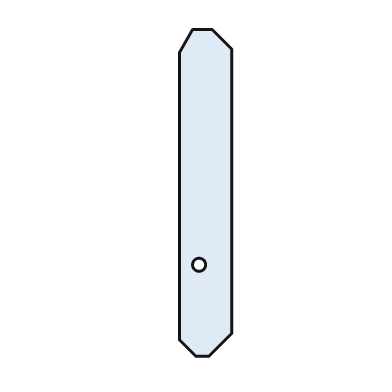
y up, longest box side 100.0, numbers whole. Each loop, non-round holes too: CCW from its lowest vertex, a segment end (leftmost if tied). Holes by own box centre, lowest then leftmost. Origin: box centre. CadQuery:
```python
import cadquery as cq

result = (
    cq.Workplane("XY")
    .moveTo(-3.0, -50.0)
    .lineTo(1.0, -50.0)
    .lineTo(8.0, -43.0)
    .lineTo(8.0, 44.0)
    .lineTo(2.0, 50.0)
    .lineTo(-4.0, 50.0)
    .lineTo(-8.0, 43.0)
    .lineTo(-8.0, -45.0)
    .close()
    .moveTo(-2.0, -22.0)
    .circle(2.0)
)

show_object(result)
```